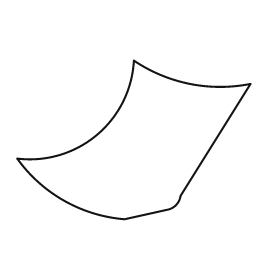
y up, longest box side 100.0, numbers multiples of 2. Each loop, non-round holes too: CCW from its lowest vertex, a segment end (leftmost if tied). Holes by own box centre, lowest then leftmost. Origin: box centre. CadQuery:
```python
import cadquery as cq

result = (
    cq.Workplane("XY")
    .moveTo(-4.0, -34.0)
    .lineTo(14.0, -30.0)
    .threePointArc((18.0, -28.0), (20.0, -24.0))
    .lineTo(50.0, 24.0)
    .threePointArc((24.0, 24.0), (0.0, 34.0))
    .threePointArc((-16.0, 2.0), (-50.0, -8.0))
    .threePointArc((-30.0, -26.0), (-4.0, -34.0))
    .close()
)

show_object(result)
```